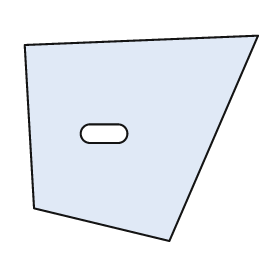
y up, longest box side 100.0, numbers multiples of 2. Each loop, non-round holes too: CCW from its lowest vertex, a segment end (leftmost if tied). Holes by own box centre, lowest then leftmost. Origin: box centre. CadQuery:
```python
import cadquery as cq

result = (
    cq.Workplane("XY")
    .moveTo(12.0, -44.0)
    .lineTo(50.0, 44.0)
    .lineTo(-50.0, 40.0)
    .lineTo(-46.0, -30.0)
    .close()
    .moveTo(-22.0, -2.0)
    .lineTo(-10.0, -2.0)
    .threePointArc((-6.0, 2.0), (-10.0, 6.0))
    .lineTo(-22.0, 6.0)
    .threePointArc((-26.0, 2.0), (-22.0, -2.0))
    .close()
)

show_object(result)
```